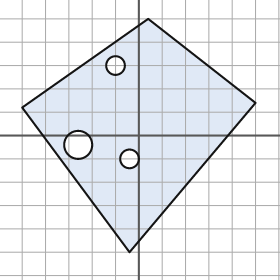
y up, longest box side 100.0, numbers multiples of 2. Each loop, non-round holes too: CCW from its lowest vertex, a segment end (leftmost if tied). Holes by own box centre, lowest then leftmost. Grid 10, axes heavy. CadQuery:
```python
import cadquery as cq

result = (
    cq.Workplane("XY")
    .moveTo(-4.0, -50.0)
    .lineTo(50.0, 14.0)
    .lineTo(4.0, 50.0)
    .lineTo(-50.0, 12.0)
    .close()
    .moveTo(-4.0, -10.0)
    .circle(4.0)
    .moveTo(-26.0, -4.0)
    .circle(6.0)
    .moveTo(-10.0, 30.0)
    .circle(4.0)
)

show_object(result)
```